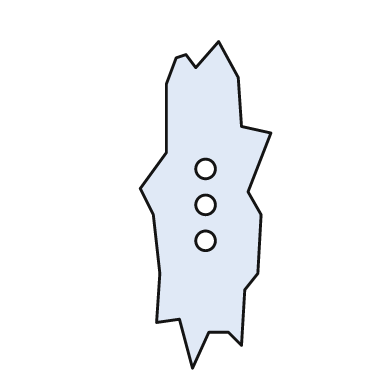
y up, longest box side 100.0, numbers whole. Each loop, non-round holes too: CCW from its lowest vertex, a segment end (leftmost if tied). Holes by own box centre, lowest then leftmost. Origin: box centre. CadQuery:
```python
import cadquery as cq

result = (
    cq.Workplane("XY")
    .moveTo(-4.0, -50.0)
    .lineTo(1.0, -39.0)
    .lineTo(7.0, -39.0)
    .lineTo(11.0, -43.0)
    .lineTo(12.0, -26.0)
    .lineTo(16.0, -21.0)
    .lineTo(17.0, -3.0)
    .lineTo(13.0, 4.0)
    .lineTo(20.0, 22.0)
    .lineTo(11.0, 24.0)
    .lineTo(10.0, 39.0)
    .lineTo(4.0, 50.0)
    .lineTo(-3.0, 42.0)
    .lineTo(-6.0, 46.0)
    .lineTo(-9.0, 45.0)
    .lineTo(-12.0, 37.0)
    .lineTo(-12.0, 16.0)
    .lineTo(-20.0, 5.0)
    .lineTo(-16.0, -3.0)
    .lineTo(-14.0, -21.0)
    .lineTo(-15.0, -36.0)
    .lineTo(-8.0, -35.0)
    .close()
    .moveTo(0.0, -11.0)
    .circle(3.0)
    .moveTo(0.0, 0.0)
    .circle(3.0)
    .moveTo(0.0, 11.0)
    .circle(3.0)
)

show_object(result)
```